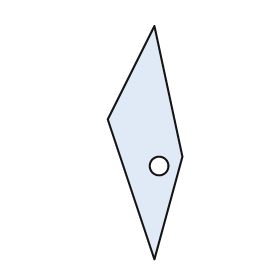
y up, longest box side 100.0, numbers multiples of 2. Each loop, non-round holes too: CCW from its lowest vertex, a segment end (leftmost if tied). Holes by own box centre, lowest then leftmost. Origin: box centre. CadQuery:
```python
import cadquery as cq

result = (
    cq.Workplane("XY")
    .moveTo(4.0, -50.0)
    .lineTo(16.0, -6.0)
    .lineTo(4.0, 50.0)
    .lineTo(-16.0, 10.0)
    .close()
    .moveTo(6.0, -10.0)
    .circle(4.0)
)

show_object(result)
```